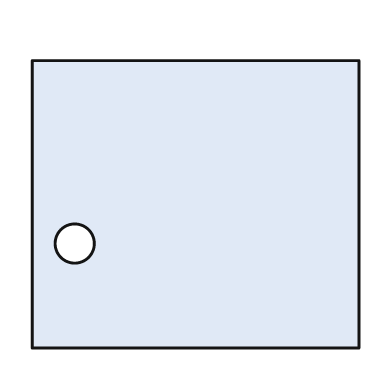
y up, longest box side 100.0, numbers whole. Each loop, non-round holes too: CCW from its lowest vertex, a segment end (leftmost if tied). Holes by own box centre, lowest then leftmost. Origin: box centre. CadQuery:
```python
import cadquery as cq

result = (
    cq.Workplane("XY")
    .moveTo(-50.0, -44.0)
    .lineTo(50.0, -44.0)
    .lineTo(50.0, 44.0)
    .lineTo(-50.0, 44.0)
    .close()
    .moveTo(-37.0, -12.0)
    .circle(6.0)
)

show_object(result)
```